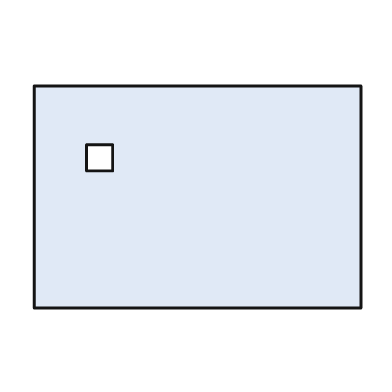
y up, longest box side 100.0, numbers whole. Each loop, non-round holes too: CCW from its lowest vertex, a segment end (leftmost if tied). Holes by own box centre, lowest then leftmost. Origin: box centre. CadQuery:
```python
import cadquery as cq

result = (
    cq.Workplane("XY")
    .moveTo(-50.0, -34.0)
    .lineTo(50.0, -34.0)
    .lineTo(50.0, 34.0)
    .lineTo(-50.0, 34.0)
    .close()
    .moveTo(-34.0, 8.0)
    .lineTo(-26.0, 8.0)
    .lineTo(-26.0, 16.0)
    .lineTo(-34.0, 16.0)
    .close()
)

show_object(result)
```